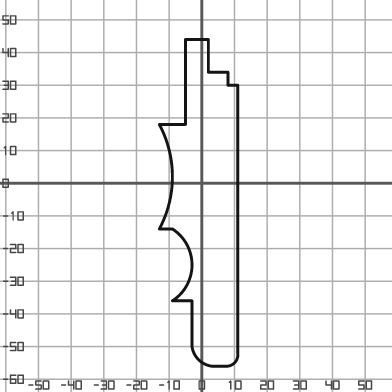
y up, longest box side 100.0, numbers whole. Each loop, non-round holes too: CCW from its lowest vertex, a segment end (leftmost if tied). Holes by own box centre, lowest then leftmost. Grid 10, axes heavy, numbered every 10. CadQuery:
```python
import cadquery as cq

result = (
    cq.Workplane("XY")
    .moveTo(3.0, -56.0)
    .lineTo(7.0, -56.0)
    .threePointArc((10.0, -55.0), (11.0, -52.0))
    .lineTo(11.0, 30.0)
    .lineTo(8.0, 30.0)
    .lineTo(8.0, 34.0)
    .lineTo(2.0, 34.0)
    .lineTo(2.0, 44.0)
    .lineTo(-5.0, 44.0)
    .lineTo(-5.0, 18.0)
    .lineTo(-13.0, 18.0)
    .threePointArc((-9.0, 2.0), (-13.0, -14.0))
    .lineTo(-9.0, -14.0)
    .threePointArc((-3.0, -25.0), (-9.0, -36.0))
    .lineTo(-3.0, -36.0)
    .lineTo(-3.0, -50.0)
    .threePointArc((-1.0, -54.0), (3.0, -56.0))
    .close()
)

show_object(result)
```